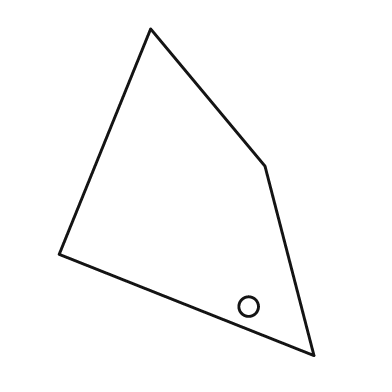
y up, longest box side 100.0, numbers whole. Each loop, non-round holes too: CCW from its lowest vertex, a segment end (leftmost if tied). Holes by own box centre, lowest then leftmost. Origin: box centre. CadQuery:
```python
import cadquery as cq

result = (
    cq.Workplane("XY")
    .moveTo(39.0, -50.0)
    .lineTo(24.0, 8.0)
    .lineTo(-11.0, 50.0)
    .lineTo(-39.0, -19.0)
    .close()
    .moveTo(19.0, -35.0)
    .circle(3.0)
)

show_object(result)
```